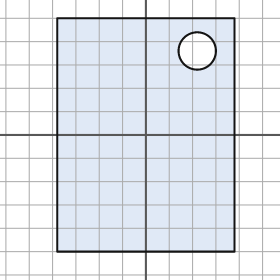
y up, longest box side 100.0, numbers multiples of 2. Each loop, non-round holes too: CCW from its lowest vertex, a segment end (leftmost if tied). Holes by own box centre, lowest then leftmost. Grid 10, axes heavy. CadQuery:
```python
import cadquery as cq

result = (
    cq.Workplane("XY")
    .moveTo(-38.0, -50.0)
    .lineTo(38.0, -50.0)
    .lineTo(38.0, 50.0)
    .lineTo(-38.0, 50.0)
    .close()
    .moveTo(22.0, 36.0)
    .circle(8.0)
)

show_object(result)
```